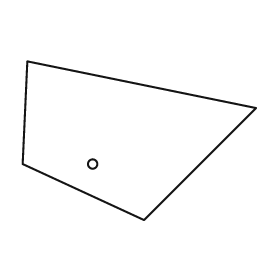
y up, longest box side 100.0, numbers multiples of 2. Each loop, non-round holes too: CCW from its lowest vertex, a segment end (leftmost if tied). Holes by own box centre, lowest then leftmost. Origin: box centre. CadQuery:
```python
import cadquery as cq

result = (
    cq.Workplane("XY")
    .moveTo(2.0, -34.0)
    .lineTo(50.0, 14.0)
    .lineTo(-48.0, 34.0)
    .lineTo(-50.0, -10.0)
    .close()
    .moveTo(-20.0, -10.0)
    .circle(2.0)
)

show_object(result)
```